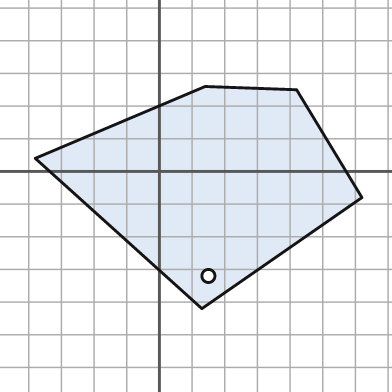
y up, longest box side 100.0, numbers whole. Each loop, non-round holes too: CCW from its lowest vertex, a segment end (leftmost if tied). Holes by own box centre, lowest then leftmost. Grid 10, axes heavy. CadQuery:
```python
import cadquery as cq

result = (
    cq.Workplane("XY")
    .moveTo(13.0, -42.0)
    .lineTo(62.0, -8.0)
    .lineTo(42.0, 25.0)
    .lineTo(14.0, 26.0)
    .lineTo(-38.0, 4.0)
    .close()
    .moveTo(15.0, -32.0)
    .circle(2.0)
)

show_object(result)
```